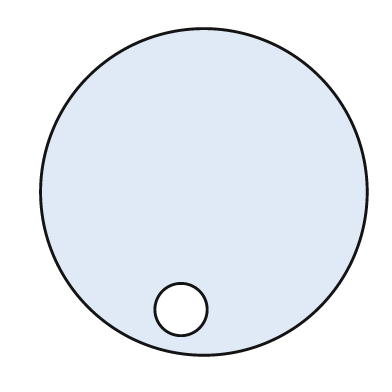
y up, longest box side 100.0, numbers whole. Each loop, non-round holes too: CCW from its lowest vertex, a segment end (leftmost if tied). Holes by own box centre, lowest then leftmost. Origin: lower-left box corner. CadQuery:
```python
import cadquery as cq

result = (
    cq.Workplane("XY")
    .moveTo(50.0, 50.0)
    .circle(50.0)
    .moveTo(43.0, 14.0)
    .circle(8.0)
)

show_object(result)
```